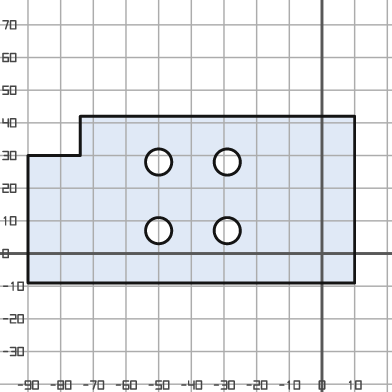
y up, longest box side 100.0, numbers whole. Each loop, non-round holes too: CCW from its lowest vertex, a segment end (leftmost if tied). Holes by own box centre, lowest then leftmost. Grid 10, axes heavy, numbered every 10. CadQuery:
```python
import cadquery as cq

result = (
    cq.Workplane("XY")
    .moveTo(-90.0, -9.0)
    .lineTo(10.0, -9.0)
    .lineTo(10.0, 42.0)
    .lineTo(-74.0, 42.0)
    .lineTo(-74.0, 30.0)
    .lineTo(-90.0, 30.0)
    .close()
    .moveTo(-50.0, 7.0)
    .circle(4.0)
    .moveTo(-29.0, 7.0)
    .circle(4.0)
    .moveTo(-50.0, 28.0)
    .circle(4.0)
    .moveTo(-29.0, 28.0)
    .circle(4.0)
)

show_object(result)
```